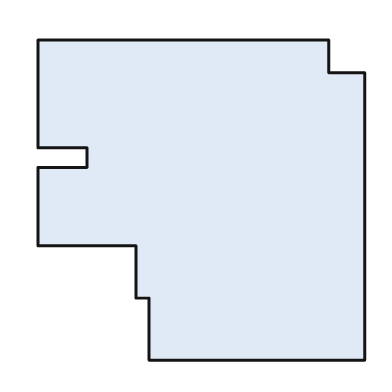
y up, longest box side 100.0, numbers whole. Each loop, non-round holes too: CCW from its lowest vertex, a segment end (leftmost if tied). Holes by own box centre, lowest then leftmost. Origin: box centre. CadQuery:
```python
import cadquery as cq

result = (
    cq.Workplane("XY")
    .moveTo(-16.0, -49.0)
    .lineTo(50.0, -49.0)
    .lineTo(50.0, 39.0)
    .lineTo(39.0, 39.0)
    .lineTo(39.0, 49.0)
    .lineTo(-50.0, 49.0)
    .lineTo(-50.0, 16.0)
    .lineTo(-35.0, 16.0)
    .lineTo(-35.0, 10.0)
    .lineTo(-50.0, 10.0)
    .lineTo(-50.0, -14.0)
    .lineTo(-20.0, -14.0)
    .lineTo(-20.0, -30.0)
    .lineTo(-16.0, -30.0)
    .close()
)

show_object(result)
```